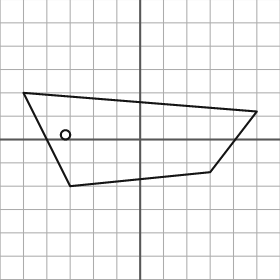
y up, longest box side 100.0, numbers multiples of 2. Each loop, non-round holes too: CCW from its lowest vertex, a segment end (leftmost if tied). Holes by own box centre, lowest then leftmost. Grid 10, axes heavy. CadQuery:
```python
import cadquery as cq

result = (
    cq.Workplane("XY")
    .moveTo(-30.0, -20.0)
    .lineTo(30.0, -14.0)
    .lineTo(50.0, 12.0)
    .lineTo(-50.0, 20.0)
    .close()
    .moveTo(-32.0, 2.0)
    .circle(2.0)
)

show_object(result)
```